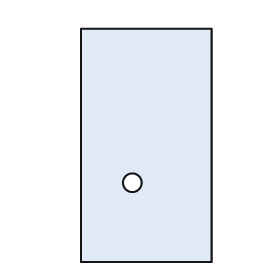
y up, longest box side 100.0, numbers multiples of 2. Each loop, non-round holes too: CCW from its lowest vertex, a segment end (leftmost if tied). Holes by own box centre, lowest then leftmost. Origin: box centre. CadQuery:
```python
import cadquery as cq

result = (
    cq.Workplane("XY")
    .moveTo(-28.0, -50.0)
    .lineTo(28.0, -50.0)
    .lineTo(28.0, 50.0)
    .lineTo(-28.0, 50.0)
    .close()
    .moveTo(-6.0, -16.0)
    .circle(4.0)
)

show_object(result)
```